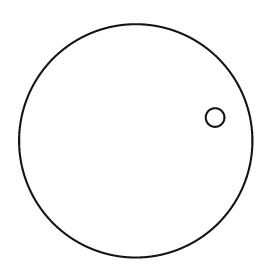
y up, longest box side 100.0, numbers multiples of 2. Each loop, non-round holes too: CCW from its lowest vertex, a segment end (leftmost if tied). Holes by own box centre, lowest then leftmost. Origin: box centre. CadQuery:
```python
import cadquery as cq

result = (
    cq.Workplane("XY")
    .moveTo(0.0, 0.0)
    .circle(50.0)
    .moveTo(34.0, 10.0)
    .circle(4.0)
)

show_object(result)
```